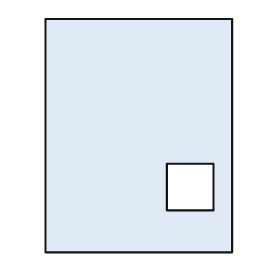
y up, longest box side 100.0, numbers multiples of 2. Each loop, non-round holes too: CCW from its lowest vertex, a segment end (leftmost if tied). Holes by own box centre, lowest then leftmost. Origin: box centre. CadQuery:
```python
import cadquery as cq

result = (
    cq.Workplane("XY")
    .moveTo(-40.0, -50.0)
    .lineTo(40.0, -50.0)
    .lineTo(40.0, 50.0)
    .lineTo(-40.0, 50.0)
    .close()
    .moveTo(12.0, -32.0)
    .lineTo(32.0, -32.0)
    .lineTo(32.0, -12.0)
    .lineTo(12.0, -12.0)
    .close()
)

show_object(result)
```